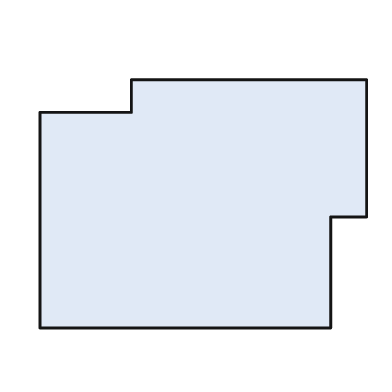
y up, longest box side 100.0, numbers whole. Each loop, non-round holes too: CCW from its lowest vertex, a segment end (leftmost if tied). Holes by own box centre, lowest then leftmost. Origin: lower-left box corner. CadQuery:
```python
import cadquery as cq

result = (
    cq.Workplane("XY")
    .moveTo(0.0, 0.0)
    .lineTo(89.0, 0.0)
    .lineTo(89.0, 34.0)
    .lineTo(100.0, 34.0)
    .lineTo(100.0, 76.0)
    .lineTo(28.0, 76.0)
    .lineTo(28.0, 66.0)
    .lineTo(0.0, 66.0)
    .close()
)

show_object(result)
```